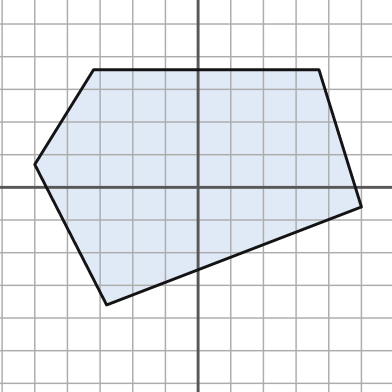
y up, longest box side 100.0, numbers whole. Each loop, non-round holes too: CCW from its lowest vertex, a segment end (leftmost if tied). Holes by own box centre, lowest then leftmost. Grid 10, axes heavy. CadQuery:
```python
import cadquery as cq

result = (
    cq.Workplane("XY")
    .moveTo(-28.0, -36.0)
    .lineTo(50.0, -6.0)
    .lineTo(37.0, 36.0)
    .lineTo(-32.0, 36.0)
    .lineTo(-50.0, 7.0)
    .close()
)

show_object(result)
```